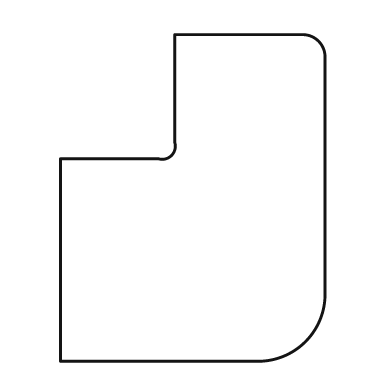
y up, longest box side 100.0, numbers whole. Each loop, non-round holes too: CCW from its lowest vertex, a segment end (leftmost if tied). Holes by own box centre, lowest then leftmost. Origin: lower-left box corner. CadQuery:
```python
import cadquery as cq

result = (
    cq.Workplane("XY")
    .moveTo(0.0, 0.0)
    .lineTo(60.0, 0.0)
    .threePointArc((75.0, 6.0), (81.0, 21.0))
    .lineTo(81.0, 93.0)
    .threePointArc((79.0, 98.0), (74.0, 100.0))
    .lineTo(35.0, 100.0)
    .lineTo(35.0, 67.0)
    .threePointArc((34.0, 63.0), (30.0, 62.0))
    .lineTo(0.0, 62.0)
    .close()
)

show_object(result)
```